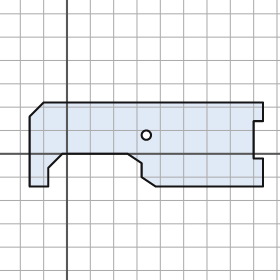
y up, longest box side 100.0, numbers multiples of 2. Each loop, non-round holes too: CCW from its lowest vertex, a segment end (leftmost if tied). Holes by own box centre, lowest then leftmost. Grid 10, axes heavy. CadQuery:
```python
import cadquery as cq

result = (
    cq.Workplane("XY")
    .moveTo(-16.0, -14.0)
    .lineTo(-8.0, -14.0)
    .lineTo(-8.0, -6.0)
    .lineTo(-2.0, 0.0)
    .lineTo(26.0, 0.0)
    .lineTo(32.0, -4.0)
    .lineTo(32.0, -10.0)
    .lineTo(38.0, -14.0)
    .lineTo(84.0, -14.0)
    .lineTo(84.0, -2.0)
    .lineTo(80.0, -2.0)
    .lineTo(80.0, 14.0)
    .lineTo(84.0, 14.0)
    .lineTo(84.0, 22.0)
    .lineTo(-10.0, 22.0)
    .lineTo(-16.0, 16.0)
    .close()
    .moveTo(34.0, 8.0)
    .circle(2.0)
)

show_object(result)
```